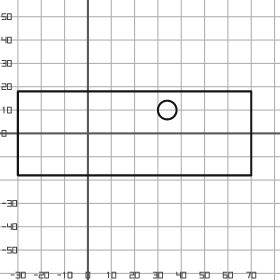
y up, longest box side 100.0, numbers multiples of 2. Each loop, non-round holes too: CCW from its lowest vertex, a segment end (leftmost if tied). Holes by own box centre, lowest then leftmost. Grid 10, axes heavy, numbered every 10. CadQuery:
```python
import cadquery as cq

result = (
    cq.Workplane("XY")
    .moveTo(-30.0, -18.0)
    .lineTo(70.0, -18.0)
    .lineTo(70.0, 18.0)
    .lineTo(-30.0, 18.0)
    .close()
    .moveTo(34.0, 10.0)
    .circle(4.0)
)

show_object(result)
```